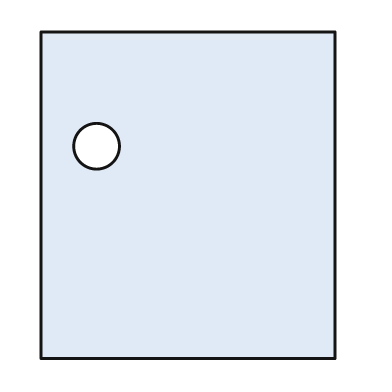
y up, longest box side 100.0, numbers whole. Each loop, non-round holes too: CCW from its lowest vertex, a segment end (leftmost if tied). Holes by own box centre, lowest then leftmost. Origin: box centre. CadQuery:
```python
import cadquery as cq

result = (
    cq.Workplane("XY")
    .moveTo(-45.0, -50.0)
    .lineTo(45.0, -50.0)
    .lineTo(45.0, 50.0)
    .lineTo(-45.0, 50.0)
    .close()
    .moveTo(-28.0, 15.0)
    .circle(7.0)
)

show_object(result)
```